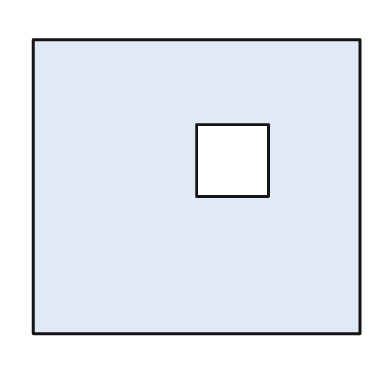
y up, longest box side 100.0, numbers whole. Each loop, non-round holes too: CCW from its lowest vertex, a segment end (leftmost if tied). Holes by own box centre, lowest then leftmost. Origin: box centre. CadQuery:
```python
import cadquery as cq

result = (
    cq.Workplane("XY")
    .moveTo(-50.0, -45.0)
    .lineTo(50.0, -45.0)
    .lineTo(50.0, 45.0)
    .lineTo(-50.0, 45.0)
    .close()
    .moveTo(0.0, -3.0)
    .lineTo(22.0, -3.0)
    .lineTo(22.0, 19.0)
    .lineTo(0.0, 19.0)
    .close()
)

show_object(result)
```